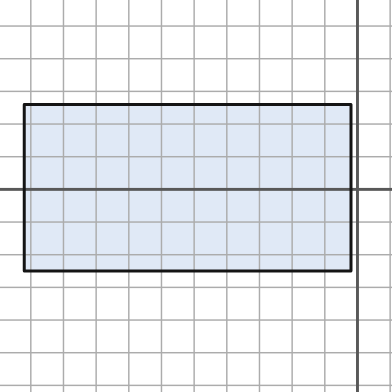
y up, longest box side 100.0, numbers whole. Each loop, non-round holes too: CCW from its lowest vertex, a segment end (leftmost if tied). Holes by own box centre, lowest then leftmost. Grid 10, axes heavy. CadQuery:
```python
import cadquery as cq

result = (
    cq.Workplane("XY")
    .moveTo(-102.0, -25.0)
    .lineTo(-2.0, -25.0)
    .lineTo(-2.0, 26.0)
    .lineTo(-102.0, 26.0)
    .close()
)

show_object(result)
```